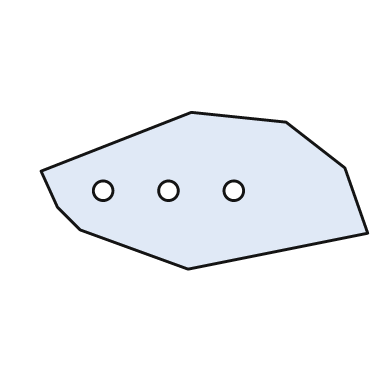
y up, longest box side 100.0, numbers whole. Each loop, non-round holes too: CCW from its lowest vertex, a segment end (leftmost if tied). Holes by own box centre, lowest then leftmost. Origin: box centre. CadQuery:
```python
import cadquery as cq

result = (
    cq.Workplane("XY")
    .moveTo(-5.0, -24.0)
    .lineTo(50.0, -13.0)
    .lineTo(43.0, 7.0)
    .lineTo(25.0, 21.0)
    .lineTo(-4.0, 24.0)
    .lineTo(-50.0, 6.0)
    .lineTo(-45.0, -5.0)
    .lineTo(-38.0, -12.0)
    .close()
    .moveTo(-31.0, 0.0)
    .circle(3.0)
    .moveTo(-11.0, 0.0)
    .circle(3.0)
    .moveTo(9.0, 0.0)
    .circle(3.0)
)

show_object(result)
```